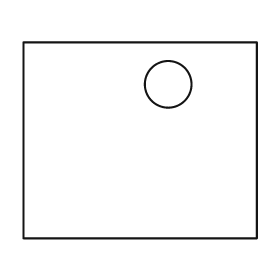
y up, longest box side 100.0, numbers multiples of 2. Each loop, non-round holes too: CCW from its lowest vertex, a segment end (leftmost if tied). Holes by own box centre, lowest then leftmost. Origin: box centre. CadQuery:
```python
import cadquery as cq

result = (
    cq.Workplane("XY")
    .moveTo(-50.0, -42.0)
    .lineTo(50.0, -42.0)
    .lineTo(50.0, 42.0)
    .lineTo(-50.0, 42.0)
    .close()
    .moveTo(12.0, 24.0)
    .circle(10.0)
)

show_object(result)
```